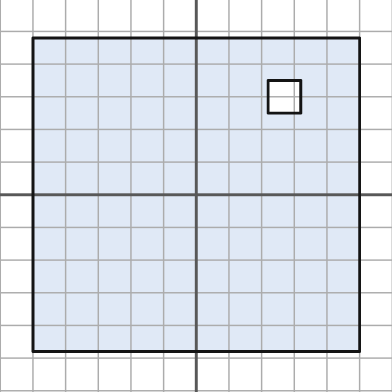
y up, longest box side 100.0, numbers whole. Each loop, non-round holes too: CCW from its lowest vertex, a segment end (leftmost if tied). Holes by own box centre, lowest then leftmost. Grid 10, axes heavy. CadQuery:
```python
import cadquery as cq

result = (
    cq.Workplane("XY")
    .moveTo(-50.0, -48.0)
    .lineTo(50.0, -48.0)
    .lineTo(50.0, 48.0)
    .lineTo(-50.0, 48.0)
    .close()
    .moveTo(22.0, 25.0)
    .lineTo(32.0, 25.0)
    .lineTo(32.0, 35.0)
    .lineTo(22.0, 35.0)
    .close()
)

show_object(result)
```